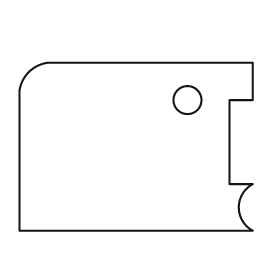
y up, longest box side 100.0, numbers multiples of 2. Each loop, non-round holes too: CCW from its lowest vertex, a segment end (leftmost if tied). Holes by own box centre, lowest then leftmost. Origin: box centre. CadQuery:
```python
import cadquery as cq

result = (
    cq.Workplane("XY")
    .moveTo(-50.0, -36.0)
    .lineTo(50.0, -36.0)
    .threePointArc((44.0, -26.0), (50.0, -16.0))
    .lineTo(40.0, -16.0)
    .lineTo(40.0, 20.0)
    .lineTo(50.0, 20.0)
    .lineTo(50.0, 36.0)
    .lineTo(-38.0, 36.0)
    .threePointArc((-46.0, 32.0), (-50.0, 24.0))
    .close()
    .moveTo(22.0, 20.0)
    .circle(6.0)
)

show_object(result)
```